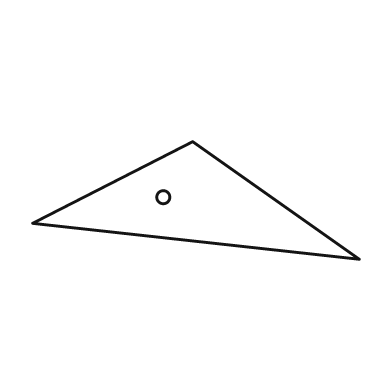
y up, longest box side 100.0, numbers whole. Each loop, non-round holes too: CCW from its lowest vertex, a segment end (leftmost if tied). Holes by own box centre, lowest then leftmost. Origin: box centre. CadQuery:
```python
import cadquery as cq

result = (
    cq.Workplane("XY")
    .moveTo(50.0, -18.0)
    .lineTo(-1.0, 18.0)
    .lineTo(-50.0, -7.0)
    .close()
    .moveTo(-10.0, 1.0)
    .circle(2.0)
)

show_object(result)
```